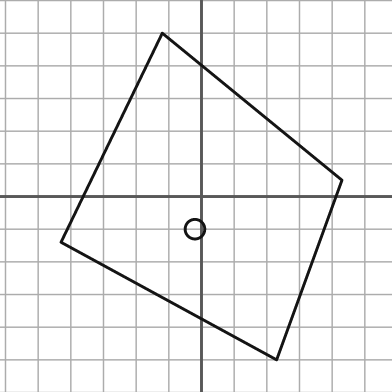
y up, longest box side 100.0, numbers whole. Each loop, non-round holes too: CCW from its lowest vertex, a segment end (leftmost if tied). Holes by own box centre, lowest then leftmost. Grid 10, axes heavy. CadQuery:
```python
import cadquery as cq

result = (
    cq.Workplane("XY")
    .moveTo(23.0, -50.0)
    .lineTo(43.0, 5.0)
    .lineTo(-12.0, 50.0)
    .lineTo(-43.0, -14.0)
    .close()
    .moveTo(-2.0, -10.0)
    .circle(3.0)
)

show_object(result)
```